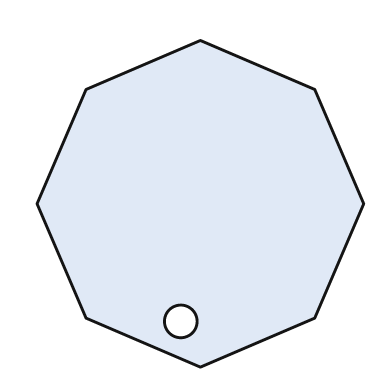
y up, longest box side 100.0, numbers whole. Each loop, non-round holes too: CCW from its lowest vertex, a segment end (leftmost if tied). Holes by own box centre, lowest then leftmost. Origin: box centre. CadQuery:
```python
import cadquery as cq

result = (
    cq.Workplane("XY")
    .moveTo(0.0, -50.0)
    .lineTo(35.0, -35.0)
    .lineTo(50.0, 0.0)
    .lineTo(35.0, 35.0)
    .lineTo(0.0, 50.0)
    .lineTo(-35.0, 35.0)
    .lineTo(-50.0, 0.0)
    .lineTo(-35.0, -35.0)
    .close()
    .moveTo(-6.0, -36.0)
    .circle(5.0)
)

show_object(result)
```